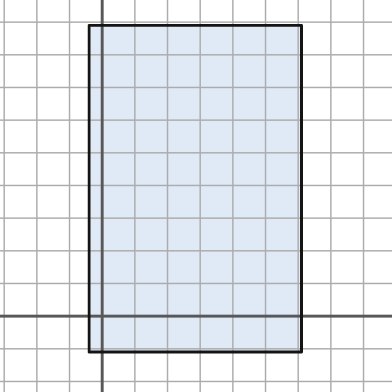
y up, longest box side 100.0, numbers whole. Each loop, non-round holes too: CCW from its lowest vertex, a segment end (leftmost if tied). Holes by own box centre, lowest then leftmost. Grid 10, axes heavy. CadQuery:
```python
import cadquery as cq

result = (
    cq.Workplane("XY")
    .moveTo(-4.0, -11.0)
    .lineTo(61.0, -11.0)
    .lineTo(61.0, 89.0)
    .lineTo(-4.0, 89.0)
    .close()
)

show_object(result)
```